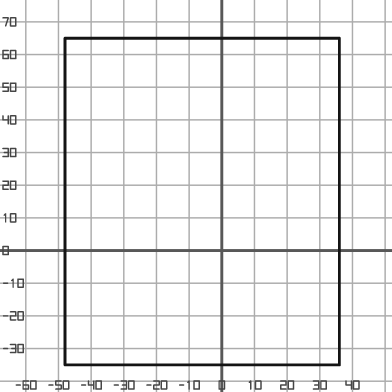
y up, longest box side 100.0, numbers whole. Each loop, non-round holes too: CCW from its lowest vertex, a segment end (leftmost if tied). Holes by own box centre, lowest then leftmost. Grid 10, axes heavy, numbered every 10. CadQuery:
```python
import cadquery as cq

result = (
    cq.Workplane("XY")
    .moveTo(-48.0, -35.0)
    .lineTo(36.0, -35.0)
    .lineTo(36.0, 65.0)
    .lineTo(-48.0, 65.0)
    .close()
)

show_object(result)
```